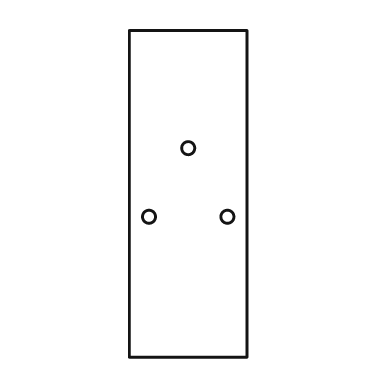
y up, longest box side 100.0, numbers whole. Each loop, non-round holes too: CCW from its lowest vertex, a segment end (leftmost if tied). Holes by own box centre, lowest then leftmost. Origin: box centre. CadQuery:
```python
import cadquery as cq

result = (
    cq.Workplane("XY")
    .moveTo(-18.0, -50.0)
    .lineTo(18.0, -50.0)
    .lineTo(18.0, 50.0)
    .lineTo(-18.0, 50.0)
    .close()
    .moveTo(-12.0, -7.0)
    .circle(2.0)
    .moveTo(12.0, -7.0)
    .circle(2.0)
    .moveTo(0.0, 14.0)
    .circle(2.0)
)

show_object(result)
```